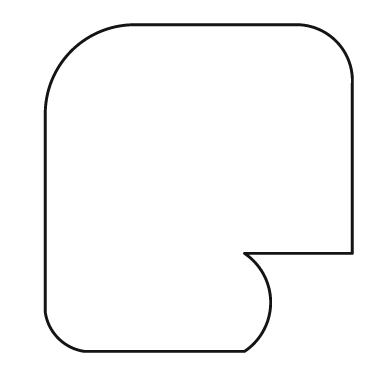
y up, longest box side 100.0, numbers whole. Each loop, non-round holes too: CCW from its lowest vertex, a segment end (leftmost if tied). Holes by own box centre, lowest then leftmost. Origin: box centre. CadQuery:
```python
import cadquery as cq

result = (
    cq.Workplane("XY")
    .moveTo(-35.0, -50.0)
    .lineTo(14.0, -50.0)
    .threePointArc((22.0, -35.0), (14.0, -20.0))
    .lineTo(47.0, -20.0)
    .lineTo(47.0, 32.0)
    .threePointArc((42.0, 45.0), (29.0, 50.0))
    .lineTo(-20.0, 50.0)
    .threePointArc((-39.0, 42.0), (-47.0, 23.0))
    .lineTo(-47.0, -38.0)
    .threePointArc((-43.0, -46.0), (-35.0, -50.0))
    .close()
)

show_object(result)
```